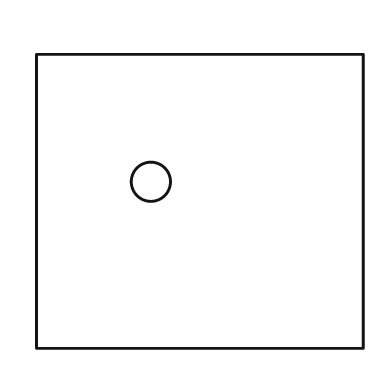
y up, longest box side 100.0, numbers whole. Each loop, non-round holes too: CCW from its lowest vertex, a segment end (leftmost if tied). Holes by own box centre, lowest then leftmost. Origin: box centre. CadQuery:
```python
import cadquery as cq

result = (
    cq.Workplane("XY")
    .moveTo(-50.0, -45.0)
    .lineTo(50.0, -45.0)
    .lineTo(50.0, 45.0)
    .lineTo(-50.0, 45.0)
    .close()
    .moveTo(-15.0, 6.0)
    .circle(6.0)
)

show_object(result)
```